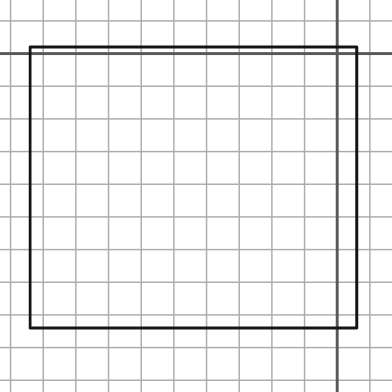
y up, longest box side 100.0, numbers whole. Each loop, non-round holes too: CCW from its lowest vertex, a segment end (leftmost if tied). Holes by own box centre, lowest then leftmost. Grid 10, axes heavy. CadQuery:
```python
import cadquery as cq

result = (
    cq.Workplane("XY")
    .moveTo(-94.0, -84.0)
    .lineTo(6.0, -84.0)
    .lineTo(6.0, 2.0)
    .lineTo(-94.0, 2.0)
    .close()
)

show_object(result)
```